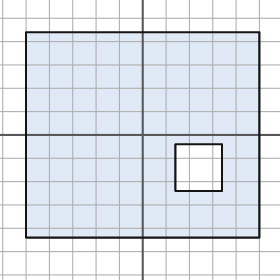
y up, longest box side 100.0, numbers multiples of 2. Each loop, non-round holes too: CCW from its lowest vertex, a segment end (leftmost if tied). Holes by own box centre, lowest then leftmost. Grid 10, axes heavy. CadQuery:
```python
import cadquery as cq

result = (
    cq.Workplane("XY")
    .moveTo(-50.0, -44.0)
    .lineTo(50.0, -44.0)
    .lineTo(50.0, 44.0)
    .lineTo(-50.0, 44.0)
    .close()
    .moveTo(14.0, -24.0)
    .lineTo(34.0, -24.0)
    .lineTo(34.0, -4.0)
    .lineTo(14.0, -4.0)
    .close()
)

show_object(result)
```